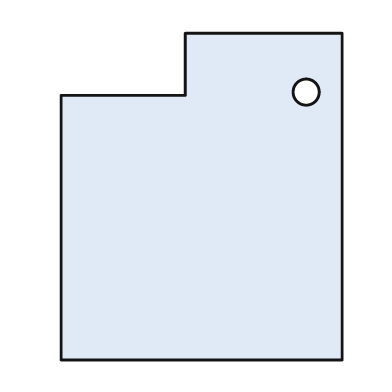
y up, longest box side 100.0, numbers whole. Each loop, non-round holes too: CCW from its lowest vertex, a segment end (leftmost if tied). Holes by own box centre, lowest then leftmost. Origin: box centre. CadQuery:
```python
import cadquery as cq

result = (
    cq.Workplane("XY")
    .moveTo(-43.0, -50.0)
    .lineTo(43.0, -50.0)
    .lineTo(43.0, 50.0)
    .lineTo(-5.0, 50.0)
    .lineTo(-5.0, 31.0)
    .lineTo(-43.0, 31.0)
    .close()
    .moveTo(32.0, 32.0)
    .circle(4.0)
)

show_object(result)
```